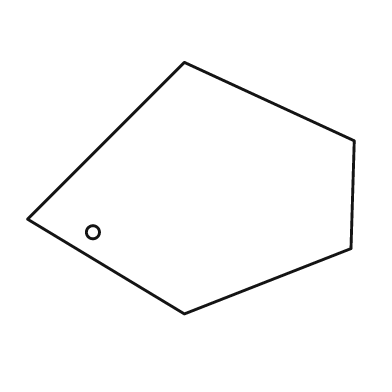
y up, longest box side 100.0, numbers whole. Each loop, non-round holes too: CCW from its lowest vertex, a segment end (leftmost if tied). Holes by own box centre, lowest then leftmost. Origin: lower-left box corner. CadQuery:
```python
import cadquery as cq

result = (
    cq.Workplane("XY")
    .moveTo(48.0, 0.0)
    .lineTo(99.0, 20.0)
    .lineTo(100.0, 53.0)
    .lineTo(48.0, 77.0)
    .lineTo(0.0, 29.0)
    .close()
    .moveTo(20.0, 25.0)
    .circle(2.0)
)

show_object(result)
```